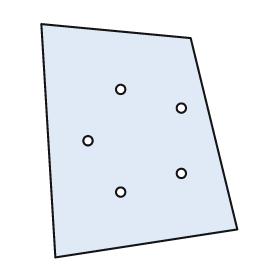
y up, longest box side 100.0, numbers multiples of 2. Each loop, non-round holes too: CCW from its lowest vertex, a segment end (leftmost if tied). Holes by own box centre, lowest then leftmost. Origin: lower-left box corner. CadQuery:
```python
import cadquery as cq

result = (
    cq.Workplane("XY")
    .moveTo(6.0, 0.0)
    .lineTo(84.0, 12.0)
    .lineTo(64.0, 94.0)
    .lineTo(0.0, 100.0)
    .close()
    .moveTo(34.0, 28.0)
    .circle(2.0)
    .moveTo(60.0, 36.0)
    .circle(2.0)
    .moveTo(20.0, 50.0)
    .circle(2.0)
    .moveTo(60.0, 64.0)
    .circle(2.0)
    .moveTo(34.0, 72.0)
    .circle(2.0)
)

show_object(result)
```